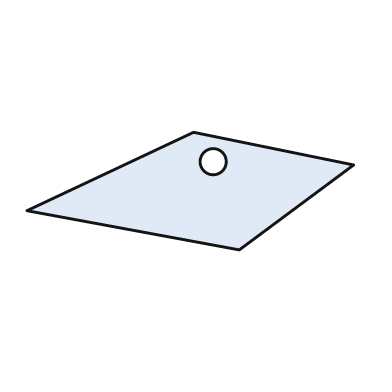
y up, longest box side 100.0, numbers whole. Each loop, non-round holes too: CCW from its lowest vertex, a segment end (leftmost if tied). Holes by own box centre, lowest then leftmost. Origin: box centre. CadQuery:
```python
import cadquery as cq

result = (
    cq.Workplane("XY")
    .moveTo(15.0, -18.0)
    .lineTo(50.0, 8.0)
    .lineTo(1.0, 18.0)
    .lineTo(-50.0, -6.0)
    .close()
    .moveTo(7.0, 9.0)
    .circle(4.0)
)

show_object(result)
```